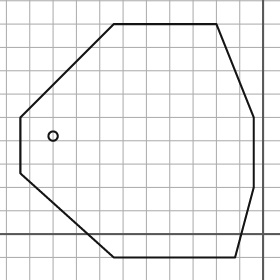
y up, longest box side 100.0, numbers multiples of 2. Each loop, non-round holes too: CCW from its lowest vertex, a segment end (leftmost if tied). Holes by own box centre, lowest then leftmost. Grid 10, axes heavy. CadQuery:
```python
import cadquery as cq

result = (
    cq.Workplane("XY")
    .moveTo(-64.0, -10.0)
    .lineTo(-12.0, -10.0)
    .lineTo(-4.0, 20.0)
    .lineTo(-4.0, 50.0)
    .lineTo(-20.0, 90.0)
    .lineTo(-64.0, 90.0)
    .lineTo(-104.0, 50.0)
    .lineTo(-104.0, 26.0)
    .close()
    .moveTo(-90.0, 42.0)
    .circle(2.0)
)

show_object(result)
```